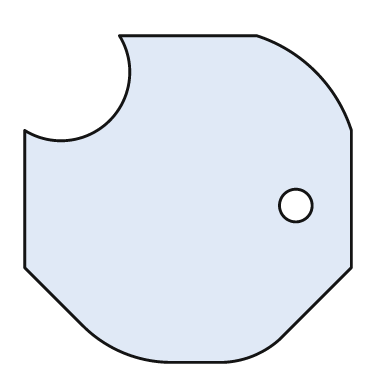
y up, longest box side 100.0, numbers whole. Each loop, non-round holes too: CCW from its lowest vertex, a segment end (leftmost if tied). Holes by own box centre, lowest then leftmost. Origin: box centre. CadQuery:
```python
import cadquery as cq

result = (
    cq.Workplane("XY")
    .moveTo(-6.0, -50.0)
    .lineTo(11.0, -50.0)
    .threePointArc((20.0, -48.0), (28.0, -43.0))
    .lineTo(50.0, -21.0)
    .lineTo(50.0, 21.0)
    .threePointArc((39.0, 39.0), (21.0, 50.0))
    .lineTo(-21.0, 50.0)
    .threePointArc((-24.0, 24.0), (-50.0, 21.0))
    .lineTo(-50.0, -21.0)
    .lineTo(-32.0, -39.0)
    .threePointArc((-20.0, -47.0), (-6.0, -50.0))
    .close()
    .moveTo(33.0, -2.0)
    .circle(5.0)
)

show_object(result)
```